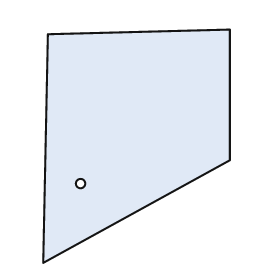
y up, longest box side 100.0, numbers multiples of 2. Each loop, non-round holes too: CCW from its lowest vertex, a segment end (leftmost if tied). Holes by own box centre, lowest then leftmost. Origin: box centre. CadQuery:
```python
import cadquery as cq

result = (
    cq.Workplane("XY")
    .moveTo(-40.0, -50.0)
    .lineTo(40.0, -6.0)
    .lineTo(40.0, 50.0)
    .lineTo(-38.0, 48.0)
    .close()
    .moveTo(-24.0, -16.0)
    .circle(2.0)
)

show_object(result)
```